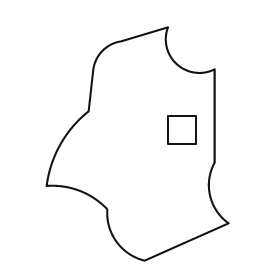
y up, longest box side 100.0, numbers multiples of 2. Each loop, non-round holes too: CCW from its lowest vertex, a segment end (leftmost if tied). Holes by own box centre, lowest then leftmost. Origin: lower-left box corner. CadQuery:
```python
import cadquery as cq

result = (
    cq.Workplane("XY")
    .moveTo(42.0, 0.0)
    .lineTo(78.0, 16.0)
    .threePointArc((70.0, 28.0), (72.0, 42.0))
    .lineTo(72.0, 82.0)
    .threePointArc((56.0, 84.0), (52.0, 100.0))
    .lineTo(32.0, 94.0)
    .threePointArc((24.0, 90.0), (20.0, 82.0))
    .lineTo(18.0, 64.0)
    .threePointArc((6.0, 50.0), (0.0, 32.0))
    .threePointArc((14.0, 30.0), (26.0, 22.0))
    .threePointArc((30.0, 8.0), (42.0, 0.0))
    .close()
    .moveTo(52.0, 50.0)
    .lineTo(64.0, 50.0)
    .lineTo(64.0, 62.0)
    .lineTo(52.0, 62.0)
    .close()
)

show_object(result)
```